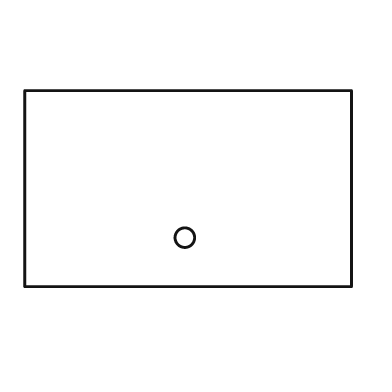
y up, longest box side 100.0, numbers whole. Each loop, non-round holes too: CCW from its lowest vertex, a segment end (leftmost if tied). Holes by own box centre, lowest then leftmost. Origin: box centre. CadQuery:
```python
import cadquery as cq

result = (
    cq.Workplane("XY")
    .moveTo(-50.0, -30.0)
    .lineTo(50.0, -30.0)
    .lineTo(50.0, 30.0)
    .lineTo(-50.0, 30.0)
    .close()
    .moveTo(-1.0, -15.0)
    .circle(3.0)
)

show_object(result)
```